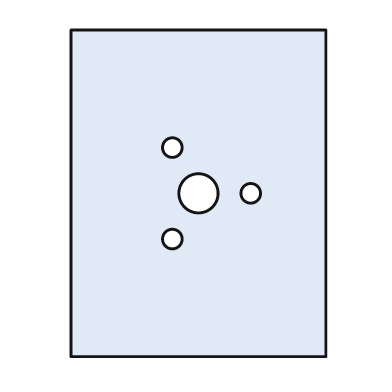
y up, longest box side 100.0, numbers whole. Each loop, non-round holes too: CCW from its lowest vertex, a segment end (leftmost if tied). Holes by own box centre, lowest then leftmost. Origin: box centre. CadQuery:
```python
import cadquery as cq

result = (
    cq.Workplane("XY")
    .moveTo(-39.0, -50.0)
    .lineTo(39.0, -50.0)
    .lineTo(39.0, 50.0)
    .lineTo(-39.0, 50.0)
    .close()
    .moveTo(-8.0, -14.0)
    .circle(3.0)
    .moveTo(0.0, 0.0)
    .circle(6.0)
    .moveTo(16.0, 0.0)
    .circle(3.0)
    .moveTo(-8.0, 14.0)
    .circle(3.0)
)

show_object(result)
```